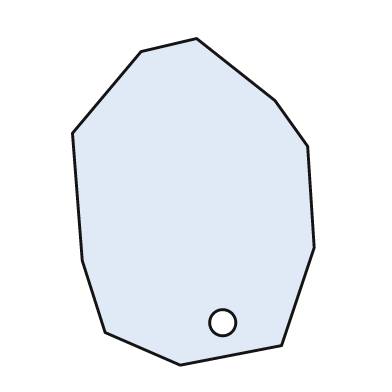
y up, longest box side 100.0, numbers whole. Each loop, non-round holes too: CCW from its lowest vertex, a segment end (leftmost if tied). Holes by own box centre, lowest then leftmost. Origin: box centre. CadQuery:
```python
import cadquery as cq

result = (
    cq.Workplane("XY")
    .moveTo(-4.0, -50.0)
    .lineTo(27.0, -44.0)
    .lineTo(37.0, -14.0)
    .lineTo(35.0, 17.0)
    .lineTo(25.0, 31.0)
    .lineTo(1.0, 50.0)
    .lineTo(-16.0, 46.0)
    .lineTo(-37.0, 21.0)
    .lineTo(-34.0, -18.0)
    .lineTo(-27.0, -40.0)
    .close()
    .moveTo(9.0, -37.0)
    .circle(4.0)
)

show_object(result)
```